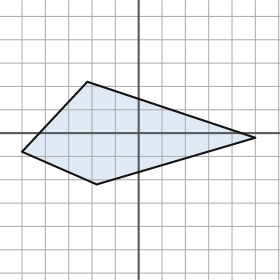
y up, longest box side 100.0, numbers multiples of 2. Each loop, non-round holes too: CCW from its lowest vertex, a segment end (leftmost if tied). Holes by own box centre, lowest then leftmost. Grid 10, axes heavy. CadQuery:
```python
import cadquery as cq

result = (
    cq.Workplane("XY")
    .moveTo(-18.0, -22.0)
    .lineTo(50.0, -2.0)
    .lineTo(-22.0, 22.0)
    .lineTo(-50.0, -8.0)
    .close()
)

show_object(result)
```